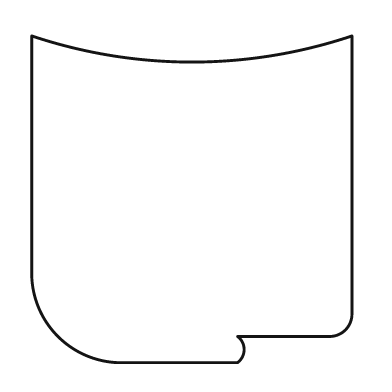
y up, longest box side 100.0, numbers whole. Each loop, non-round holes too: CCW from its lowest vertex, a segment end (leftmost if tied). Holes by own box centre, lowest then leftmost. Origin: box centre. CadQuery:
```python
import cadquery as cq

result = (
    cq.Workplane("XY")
    .moveTo(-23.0, -50.0)
    .lineTo(14.0, -50.0)
    .threePointArc((16.0, -46.0), (14.0, -42.0))
    .lineTo(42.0, -42.0)
    .threePointArc((47.0, -40.0), (49.0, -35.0))
    .lineTo(49.0, 50.0)
    .threePointArc((0.0, 42.0), (-49.0, 50.0))
    .lineTo(-49.0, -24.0)
    .threePointArc((-41.0, -42.0), (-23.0, -50.0))
    .close()
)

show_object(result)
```